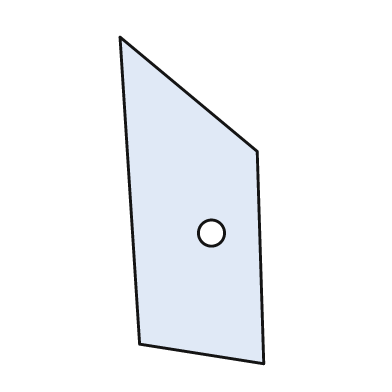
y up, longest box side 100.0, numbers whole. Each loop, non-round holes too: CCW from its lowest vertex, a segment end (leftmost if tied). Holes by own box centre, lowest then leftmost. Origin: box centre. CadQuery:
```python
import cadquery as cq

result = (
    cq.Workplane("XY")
    .moveTo(22.0, -50.0)
    .lineTo(20.0, 15.0)
    .lineTo(-22.0, 50.0)
    .lineTo(-16.0, -44.0)
    .close()
    .moveTo(6.0, -10.0)
    .circle(4.0)
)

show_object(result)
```